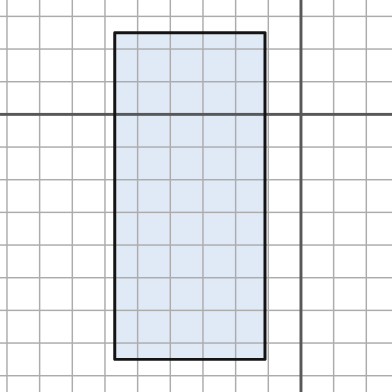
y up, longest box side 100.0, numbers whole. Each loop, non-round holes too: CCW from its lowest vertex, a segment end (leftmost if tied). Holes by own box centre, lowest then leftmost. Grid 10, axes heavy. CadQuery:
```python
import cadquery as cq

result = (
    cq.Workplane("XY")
    .moveTo(-57.0, -75.0)
    .lineTo(-11.0, -75.0)
    .lineTo(-11.0, 25.0)
    .lineTo(-57.0, 25.0)
    .close()
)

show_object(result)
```